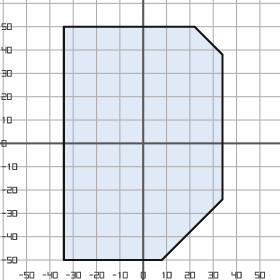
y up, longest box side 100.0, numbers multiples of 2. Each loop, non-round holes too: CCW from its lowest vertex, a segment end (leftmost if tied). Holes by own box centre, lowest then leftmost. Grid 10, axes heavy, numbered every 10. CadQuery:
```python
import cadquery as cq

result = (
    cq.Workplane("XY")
    .moveTo(-34.0, -50.0)
    .lineTo(8.0, -50.0)
    .lineTo(34.0, -24.0)
    .lineTo(34.0, 38.0)
    .lineTo(22.0, 50.0)
    .lineTo(-34.0, 50.0)
    .close()
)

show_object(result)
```